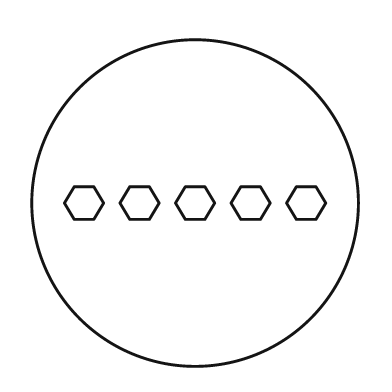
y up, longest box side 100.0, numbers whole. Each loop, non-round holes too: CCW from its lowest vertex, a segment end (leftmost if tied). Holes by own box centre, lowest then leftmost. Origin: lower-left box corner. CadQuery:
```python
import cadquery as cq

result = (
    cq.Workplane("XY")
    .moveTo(50.0, 50.0)
    .circle(50.0)
    .moveTo(13.0, 45.0)
    .lineTo(19.0, 45.0)
    .lineTo(22.0, 50.0)
    .lineTo(19.0, 55.0)
    .lineTo(13.0, 55.0)
    .lineTo(10.0, 50.0)
    .close()
    .moveTo(30.0, 45.0)
    .lineTo(36.0, 45.0)
    .lineTo(39.0, 50.0)
    .lineTo(36.0, 55.0)
    .lineTo(30.0, 55.0)
    .lineTo(27.0, 50.0)
    .close()
    .moveTo(47.0, 45.0)
    .lineTo(53.0, 45.0)
    .lineTo(56.0, 50.0)
    .lineTo(53.0, 55.0)
    .lineTo(47.0, 55.0)
    .lineTo(44.0, 50.0)
    .close()
    .moveTo(64.0, 45.0)
    .lineTo(70.0, 45.0)
    .lineTo(73.0, 50.0)
    .lineTo(70.0, 55.0)
    .lineTo(64.0, 55.0)
    .lineTo(61.0, 50.0)
    .close()
    .moveTo(81.0, 45.0)
    .lineTo(87.0, 45.0)
    .lineTo(90.0, 50.0)
    .lineTo(87.0, 55.0)
    .lineTo(81.0, 55.0)
    .lineTo(78.0, 50.0)
    .close()
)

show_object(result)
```